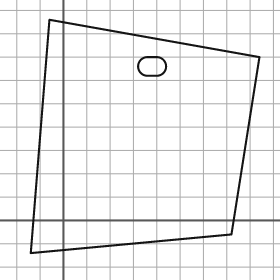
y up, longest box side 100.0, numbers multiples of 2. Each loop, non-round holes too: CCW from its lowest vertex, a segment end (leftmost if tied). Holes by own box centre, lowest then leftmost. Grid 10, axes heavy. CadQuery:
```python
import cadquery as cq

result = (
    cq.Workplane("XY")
    .moveTo(-14.0, -14.0)
    .lineTo(72.0, -6.0)
    .lineTo(84.0, 70.0)
    .lineTo(-6.0, 86.0)
    .close()
    .moveTo(36.0, 62.0)
    .lineTo(40.0, 62.0)
    .threePointArc((44.0, 66.0), (40.0, 70.0))
    .lineTo(36.0, 70.0)
    .threePointArc((32.0, 66.0), (36.0, 62.0))
    .close()
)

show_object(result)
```